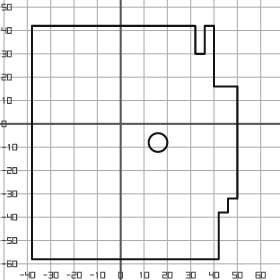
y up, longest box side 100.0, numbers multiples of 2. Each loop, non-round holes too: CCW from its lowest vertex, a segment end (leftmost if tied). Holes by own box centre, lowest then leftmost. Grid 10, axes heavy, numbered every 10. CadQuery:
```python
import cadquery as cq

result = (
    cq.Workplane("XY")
    .moveTo(-38.0, -58.0)
    .lineTo(42.0, -58.0)
    .lineTo(42.0, -38.0)
    .lineTo(46.0, -38.0)
    .lineTo(46.0, -32.0)
    .lineTo(50.0, -32.0)
    .lineTo(50.0, 16.0)
    .lineTo(40.0, 16.0)
    .lineTo(40.0, 42.0)
    .lineTo(36.0, 42.0)
    .lineTo(36.0, 30.0)
    .lineTo(32.0, 30.0)
    .lineTo(32.0, 42.0)
    .lineTo(-38.0, 42.0)
    .close()
    .moveTo(16.0, -8.0)
    .circle(4.0)
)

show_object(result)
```